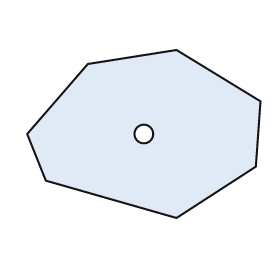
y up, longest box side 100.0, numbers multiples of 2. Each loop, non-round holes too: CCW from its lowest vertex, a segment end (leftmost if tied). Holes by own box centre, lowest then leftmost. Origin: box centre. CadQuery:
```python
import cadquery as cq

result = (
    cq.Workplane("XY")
    .moveTo(14.0, -36.0)
    .lineTo(48.0, -14.0)
    .lineTo(50.0, 14.0)
    .lineTo(14.0, 36.0)
    .lineTo(-24.0, 30.0)
    .lineTo(-50.0, 0.0)
    .lineTo(-42.0, -20.0)
    .close()
    .moveTo(0.0, 0.0)
    .circle(4.0)
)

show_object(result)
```